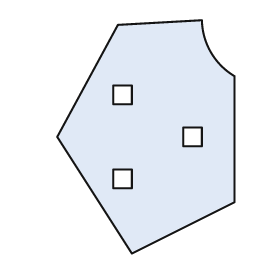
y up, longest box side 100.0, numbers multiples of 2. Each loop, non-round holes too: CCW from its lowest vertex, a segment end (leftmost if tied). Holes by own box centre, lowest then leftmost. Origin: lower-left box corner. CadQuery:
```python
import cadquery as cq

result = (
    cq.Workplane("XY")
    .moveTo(32.0, 0.0)
    .lineTo(76.0, 22.0)
    .lineTo(76.0, 76.0)
    .threePointArc((66.0, 86.0), (62.0, 100.0))
    .lineTo(26.0, 98.0)
    .lineTo(0.0, 50.0)
    .close()
    .moveTo(24.0, 28.0)
    .lineTo(32.0, 28.0)
    .lineTo(32.0, 36.0)
    .lineTo(24.0, 36.0)
    .close()
    .moveTo(54.0, 46.0)
    .lineTo(62.0, 46.0)
    .lineTo(62.0, 54.0)
    .lineTo(54.0, 54.0)
    .close()
    .moveTo(24.0, 64.0)
    .lineTo(32.0, 64.0)
    .lineTo(32.0, 72.0)
    .lineTo(24.0, 72.0)
    .close()
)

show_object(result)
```